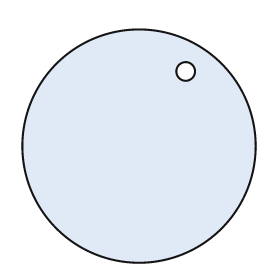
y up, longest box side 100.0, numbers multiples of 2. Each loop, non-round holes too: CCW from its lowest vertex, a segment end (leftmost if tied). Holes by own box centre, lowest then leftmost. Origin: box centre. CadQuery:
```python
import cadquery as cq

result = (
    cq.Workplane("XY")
    .moveTo(0.0, 0.0)
    .circle(50.0)
    .moveTo(20.0, 32.0)
    .circle(4.0)
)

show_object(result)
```